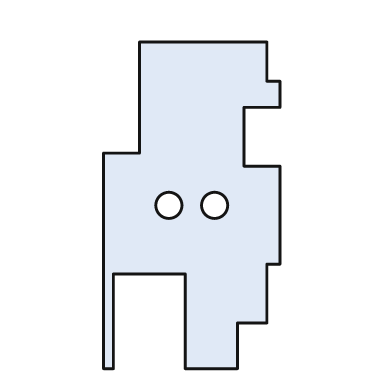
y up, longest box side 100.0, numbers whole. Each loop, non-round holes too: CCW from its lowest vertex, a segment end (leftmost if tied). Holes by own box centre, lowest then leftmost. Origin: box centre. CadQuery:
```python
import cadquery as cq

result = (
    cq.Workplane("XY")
    .moveTo(-27.0, -50.0)
    .lineTo(-24.0, -50.0)
    .lineTo(-24.0, -21.0)
    .lineTo(-2.0, -21.0)
    .lineTo(-2.0, -50.0)
    .lineTo(14.0, -50.0)
    .lineTo(14.0, -36.0)
    .lineTo(23.0, -36.0)
    .lineTo(23.0, -18.0)
    .lineTo(27.0, -18.0)
    .lineTo(27.0, 12.0)
    .lineTo(16.0, 12.0)
    .lineTo(16.0, 30.0)
    .lineTo(27.0, 30.0)
    .lineTo(27.0, 38.0)
    .lineTo(23.0, 38.0)
    .lineTo(23.0, 50.0)
    .lineTo(-16.0, 50.0)
    .lineTo(-16.0, 16.0)
    .lineTo(-27.0, 16.0)
    .close()
    .moveTo(-7.0, 0.0)
    .circle(4.0)
    .moveTo(7.0, 0.0)
    .circle(4.0)
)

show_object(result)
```